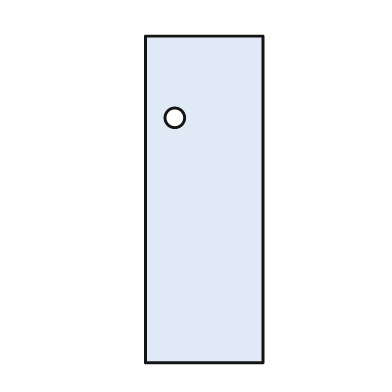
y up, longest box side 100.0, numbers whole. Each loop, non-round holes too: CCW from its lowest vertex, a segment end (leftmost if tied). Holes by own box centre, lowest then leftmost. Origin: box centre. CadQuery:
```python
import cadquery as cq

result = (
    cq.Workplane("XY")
    .moveTo(-18.0, -50.0)
    .lineTo(18.0, -50.0)
    .lineTo(18.0, 50.0)
    .lineTo(-18.0, 50.0)
    .close()
    .moveTo(-9.0, 25.0)
    .circle(3.0)
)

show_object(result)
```